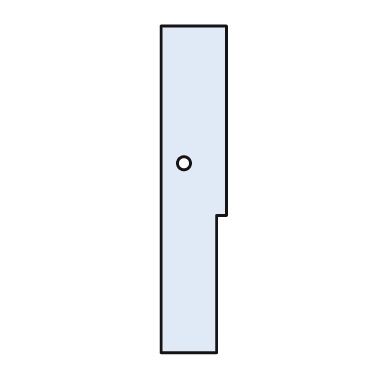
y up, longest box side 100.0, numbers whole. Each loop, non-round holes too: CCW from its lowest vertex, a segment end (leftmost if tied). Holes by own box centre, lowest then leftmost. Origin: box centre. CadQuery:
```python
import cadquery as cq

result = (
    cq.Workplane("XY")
    .moveTo(-10.0, -50.0)
    .lineTo(7.0, -50.0)
    .lineTo(7.0, -8.0)
    .lineTo(10.0, -8.0)
    .lineTo(10.0, 50.0)
    .lineTo(-10.0, 50.0)
    .close()
    .moveTo(-3.0, 8.0)
    .circle(2.0)
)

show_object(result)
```